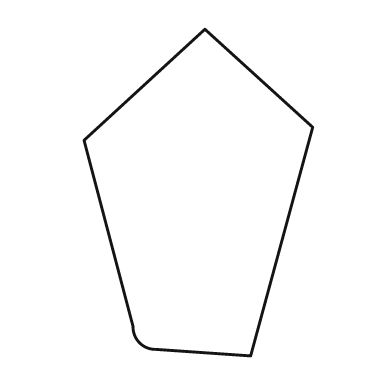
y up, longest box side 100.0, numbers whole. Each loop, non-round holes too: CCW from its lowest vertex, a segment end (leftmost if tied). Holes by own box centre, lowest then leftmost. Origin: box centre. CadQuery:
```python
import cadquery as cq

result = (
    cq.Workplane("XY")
    .moveTo(16.0, -50.0)
    .lineTo(35.0, 20.0)
    .lineTo(2.0, 50.0)
    .lineTo(-35.0, 16.0)
    .lineTo(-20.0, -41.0)
    .threePointArc((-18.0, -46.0), (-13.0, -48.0))
    .close()
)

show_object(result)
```